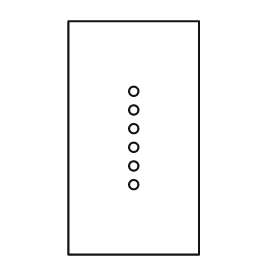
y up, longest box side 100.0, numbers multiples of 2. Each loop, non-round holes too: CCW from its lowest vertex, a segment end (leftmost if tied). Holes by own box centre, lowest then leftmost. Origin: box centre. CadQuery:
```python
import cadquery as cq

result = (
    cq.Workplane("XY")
    .moveTo(-28.0, -50.0)
    .lineTo(28.0, -50.0)
    .lineTo(28.0, 50.0)
    .lineTo(-28.0, 50.0)
    .close()
    .moveTo(0.0, -20.0)
    .circle(2.0)
    .moveTo(0.0, -12.0)
    .circle(2.0)
    .moveTo(0.0, -4.0)
    .circle(2.0)
    .moveTo(0.0, 4.0)
    .circle(2.0)
    .moveTo(0.0, 12.0)
    .circle(2.0)
    .moveTo(0.0, 20.0)
    .circle(2.0)
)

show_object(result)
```